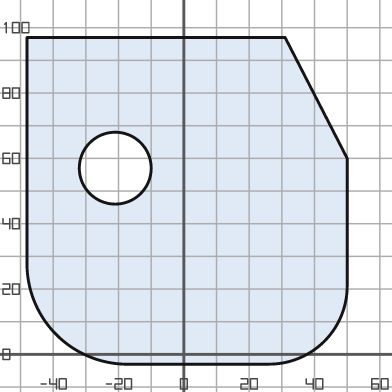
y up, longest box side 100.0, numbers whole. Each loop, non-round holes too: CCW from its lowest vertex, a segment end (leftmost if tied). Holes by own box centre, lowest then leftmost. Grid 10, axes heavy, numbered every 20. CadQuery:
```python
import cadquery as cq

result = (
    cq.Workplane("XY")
    .moveTo(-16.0, -3.0)
    .lineTo(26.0, -3.0)
    .threePointArc((43.0, 4.0), (50.0, 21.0))
    .lineTo(50.0, 60.0)
    .lineTo(31.0, 97.0)
    .lineTo(-48.0, 97.0)
    .lineTo(-48.0, 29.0)
    .threePointArc((-39.0, 6.0), (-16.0, -3.0))
    .close()
    .moveTo(-21.0, 57.0)
    .circle(11.0)
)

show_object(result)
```